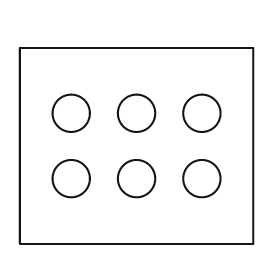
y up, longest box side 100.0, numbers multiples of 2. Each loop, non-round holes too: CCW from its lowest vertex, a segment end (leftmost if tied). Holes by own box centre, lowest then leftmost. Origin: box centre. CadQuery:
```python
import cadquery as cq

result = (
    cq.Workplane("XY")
    .moveTo(-50.0, -42.0)
    .lineTo(50.0, -42.0)
    .lineTo(50.0, 42.0)
    .lineTo(-50.0, 42.0)
    .close()
    .moveTo(-28.0, -14.0)
    .circle(8.0)
    .moveTo(0.0, -14.0)
    .circle(8.0)
    .moveTo(28.0, -14.0)
    .circle(8.0)
    .moveTo(-28.0, 14.0)
    .circle(8.0)
    .moveTo(0.0, 14.0)
    .circle(8.0)
    .moveTo(28.0, 14.0)
    .circle(8.0)
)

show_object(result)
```